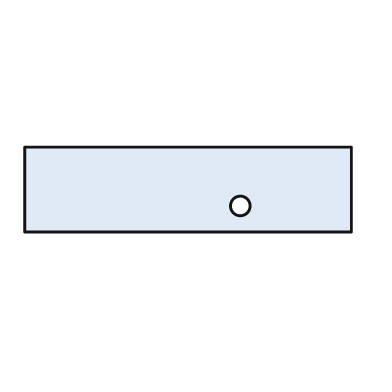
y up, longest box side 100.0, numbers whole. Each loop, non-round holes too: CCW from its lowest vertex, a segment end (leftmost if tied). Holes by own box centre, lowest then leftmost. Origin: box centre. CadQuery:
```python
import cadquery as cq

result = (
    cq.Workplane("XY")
    .moveTo(-50.0, -13.0)
    .lineTo(50.0, -13.0)
    .lineTo(50.0, 13.0)
    .lineTo(-50.0, 13.0)
    .close()
    .moveTo(16.0, -5.0)
    .circle(3.0)
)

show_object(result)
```